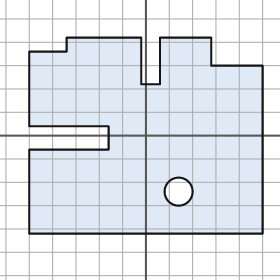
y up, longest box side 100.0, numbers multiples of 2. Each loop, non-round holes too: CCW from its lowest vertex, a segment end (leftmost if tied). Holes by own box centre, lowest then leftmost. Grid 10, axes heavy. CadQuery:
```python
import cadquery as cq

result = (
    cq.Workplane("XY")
    .moveTo(-50.0, -42.0)
    .lineTo(50.0, -42.0)
    .lineTo(50.0, 30.0)
    .lineTo(28.0, 30.0)
    .lineTo(28.0, 42.0)
    .lineTo(6.0, 42.0)
    .lineTo(6.0, 22.0)
    .lineTo(-2.0, 22.0)
    .lineTo(-2.0, 42.0)
    .lineTo(-34.0, 42.0)
    .lineTo(-34.0, 36.0)
    .lineTo(-50.0, 36.0)
    .lineTo(-50.0, 4.0)
    .lineTo(-16.0, 4.0)
    .lineTo(-16.0, -6.0)
    .lineTo(-50.0, -6.0)
    .close()
    .moveTo(14.0, -24.0)
    .circle(6.0)
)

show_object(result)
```